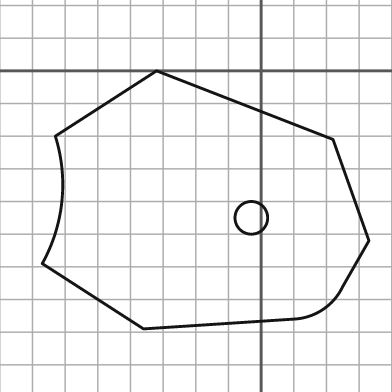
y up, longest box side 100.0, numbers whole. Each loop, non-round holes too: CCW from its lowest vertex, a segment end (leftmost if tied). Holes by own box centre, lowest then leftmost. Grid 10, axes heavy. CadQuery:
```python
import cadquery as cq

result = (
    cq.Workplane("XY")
    .moveTo(-36.0, -79.0)
    .lineTo(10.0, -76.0)
    .threePointArc((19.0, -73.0), (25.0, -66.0))
    .lineTo(33.0, -52.0)
    .lineTo(22.0, -21.0)
    .lineTo(-32.0, 0.0)
    .lineTo(-63.0, -20.0)
    .threePointArc((-61.0, -40.0), (-67.0, -59.0))
    .close()
    .moveTo(-3.0, -45.0)
    .circle(5.0)
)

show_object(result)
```